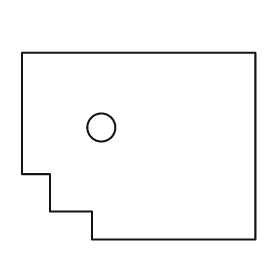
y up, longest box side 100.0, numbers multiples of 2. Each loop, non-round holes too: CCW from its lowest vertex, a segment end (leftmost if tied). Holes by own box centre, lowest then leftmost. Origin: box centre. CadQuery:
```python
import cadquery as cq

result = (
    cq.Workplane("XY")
    .moveTo(-20.0, -40.0)
    .lineTo(50.0, -40.0)
    .lineTo(50.0, 40.0)
    .lineTo(-50.0, 40.0)
    .lineTo(-50.0, -12.0)
    .lineTo(-38.0, -12.0)
    .lineTo(-38.0, -28.0)
    .lineTo(-20.0, -28.0)
    .close()
    .moveTo(-16.0, 8.0)
    .circle(6.0)
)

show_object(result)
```